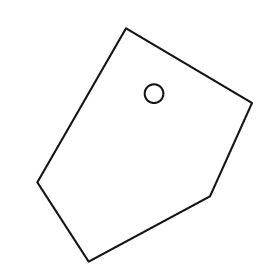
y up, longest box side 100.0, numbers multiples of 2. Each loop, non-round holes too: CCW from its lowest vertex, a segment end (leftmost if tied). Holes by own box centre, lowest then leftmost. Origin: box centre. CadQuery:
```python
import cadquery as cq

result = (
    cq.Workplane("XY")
    .moveTo(-24.0, -50.0)
    .lineTo(28.0, -22.0)
    .lineTo(46.0, 18.0)
    .lineTo(-8.0, 50.0)
    .lineTo(-46.0, -16.0)
    .close()
    .moveTo(4.0, 22.0)
    .circle(4.0)
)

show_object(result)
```